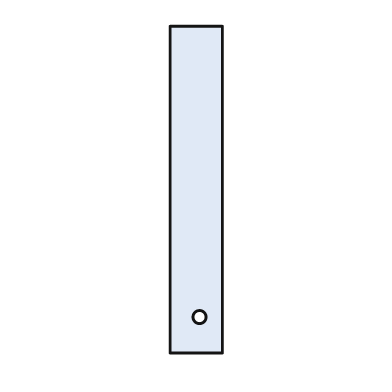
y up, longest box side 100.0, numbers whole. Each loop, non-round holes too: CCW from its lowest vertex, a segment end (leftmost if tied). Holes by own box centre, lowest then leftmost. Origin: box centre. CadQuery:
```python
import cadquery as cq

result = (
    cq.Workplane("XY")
    .moveTo(-8.0, -50.0)
    .lineTo(8.0, -50.0)
    .lineTo(8.0, 50.0)
    .lineTo(-8.0, 50.0)
    .close()
    .moveTo(1.0, -39.0)
    .circle(2.0)
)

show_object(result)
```